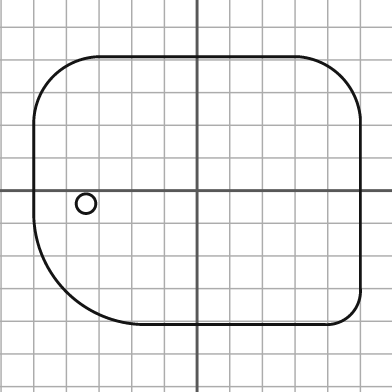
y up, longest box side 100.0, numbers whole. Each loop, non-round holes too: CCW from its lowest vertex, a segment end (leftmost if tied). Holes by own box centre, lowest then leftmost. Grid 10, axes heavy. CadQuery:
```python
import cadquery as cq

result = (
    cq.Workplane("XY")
    .moveTo(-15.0, -41.0)
    .lineTo(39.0, -41.0)
    .threePointArc((47.0, -38.0), (50.0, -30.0))
    .lineTo(50.0, 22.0)
    .threePointArc((44.0, 35.0), (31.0, 41.0))
    .lineTo(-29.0, 41.0)
    .threePointArc((-44.0, 35.0), (-50.0, 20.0))
    .lineTo(-50.0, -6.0)
    .threePointArc((-40.0, -31.0), (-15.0, -41.0))
    .close()
    .moveTo(-34.0, -4.0)
    .circle(3.0)
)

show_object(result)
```